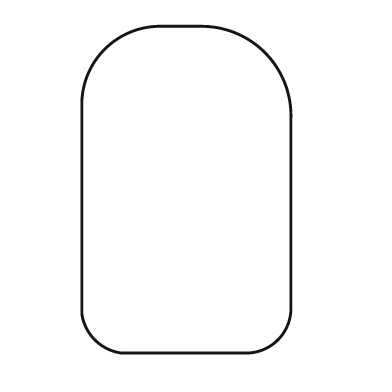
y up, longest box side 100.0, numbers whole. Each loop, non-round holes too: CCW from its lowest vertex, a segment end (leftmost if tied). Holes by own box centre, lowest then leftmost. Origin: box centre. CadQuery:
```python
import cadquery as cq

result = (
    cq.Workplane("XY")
    .moveTo(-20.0, -50.0)
    .lineTo(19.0, -50.0)
    .threePointArc((28.0, -46.0), (32.0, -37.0))
    .lineTo(32.0, 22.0)
    .threePointArc((24.0, 42.0), (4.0, 50.0))
    .lineTo(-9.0, 50.0)
    .threePointArc((-25.0, 43.0), (-32.0, 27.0))
    .lineTo(-32.0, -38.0)
    .threePointArc((-28.0, -46.0), (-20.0, -50.0))
    .close()
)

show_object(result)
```